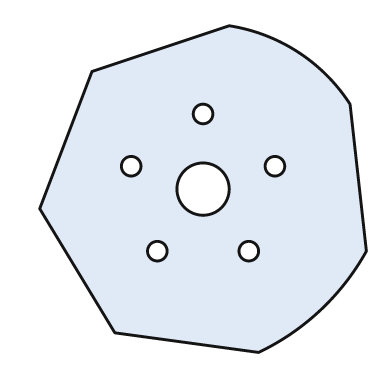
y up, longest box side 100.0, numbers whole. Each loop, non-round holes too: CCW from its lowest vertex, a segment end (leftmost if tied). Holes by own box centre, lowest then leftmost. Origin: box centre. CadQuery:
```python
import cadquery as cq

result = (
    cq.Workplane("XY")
    .moveTo(17.0, -50.0)
    .threePointArc((36.0, -37.0), (50.0, -19.0))
    .lineTo(45.0, 26.0)
    .threePointArc((29.0, 42.0), (8.0, 50.0))
    .lineTo(-34.0, 36.0)
    .lineTo(-50.0, -6.0)
    .lineTo(-27.0, -44.0)
    .close()
    .moveTo(-14.0, -19.0)
    .circle(3.0)
    .moveTo(14.0, -19.0)
    .circle(3.0)
    .moveTo(0.0, 0.0)
    .circle(8.0)
    .moveTo(-22.0, 7.0)
    .circle(3.0)
    .moveTo(22.0, 7.0)
    .circle(3.0)
    .moveTo(0.0, 23.0)
    .circle(3.0)
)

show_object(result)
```